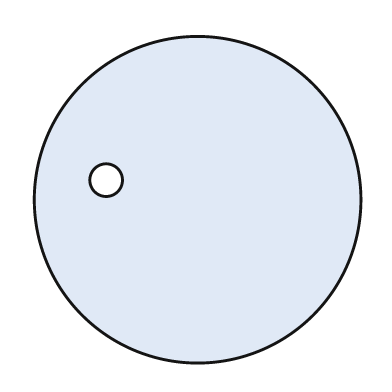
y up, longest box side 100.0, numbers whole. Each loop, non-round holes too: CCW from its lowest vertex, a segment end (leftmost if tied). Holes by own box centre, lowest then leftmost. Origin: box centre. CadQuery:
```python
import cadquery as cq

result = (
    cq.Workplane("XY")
    .moveTo(0.0, 0.0)
    .circle(50.0)
    .moveTo(-28.0, 6.0)
    .circle(5.0)
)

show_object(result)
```